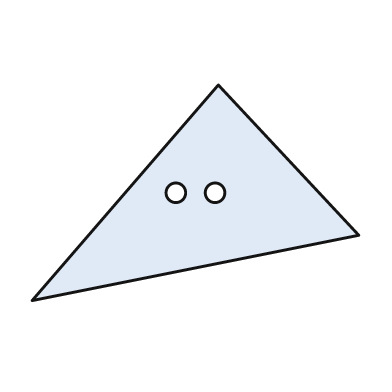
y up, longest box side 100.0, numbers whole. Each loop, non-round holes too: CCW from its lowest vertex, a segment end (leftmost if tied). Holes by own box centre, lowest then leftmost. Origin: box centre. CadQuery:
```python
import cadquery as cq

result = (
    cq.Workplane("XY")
    .moveTo(-50.0, -33.0)
    .lineTo(50.0, -13.0)
    .lineTo(7.0, 33.0)
    .close()
    .moveTo(-6.0, 0.0)
    .circle(3.0)
    .moveTo(6.0, 0.0)
    .circle(3.0)
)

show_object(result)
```